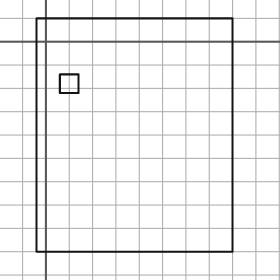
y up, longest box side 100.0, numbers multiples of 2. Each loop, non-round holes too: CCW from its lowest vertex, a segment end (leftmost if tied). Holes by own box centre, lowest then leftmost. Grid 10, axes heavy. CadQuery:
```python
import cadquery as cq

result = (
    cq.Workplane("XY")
    .moveTo(-4.0, -90.0)
    .lineTo(80.0, -90.0)
    .lineTo(80.0, 10.0)
    .lineTo(-4.0, 10.0)
    .close()
    .moveTo(6.0, -22.0)
    .lineTo(14.0, -22.0)
    .lineTo(14.0, -14.0)
    .lineTo(6.0, -14.0)
    .close()
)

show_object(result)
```